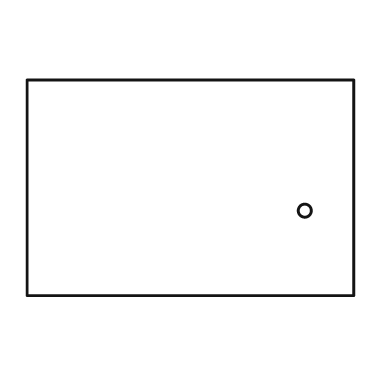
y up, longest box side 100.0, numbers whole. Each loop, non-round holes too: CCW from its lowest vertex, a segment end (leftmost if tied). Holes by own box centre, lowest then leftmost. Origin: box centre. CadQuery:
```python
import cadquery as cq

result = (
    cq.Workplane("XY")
    .moveTo(-50.0, -33.0)
    .lineTo(50.0, -33.0)
    .lineTo(50.0, 33.0)
    .lineTo(-50.0, 33.0)
    .close()
    .moveTo(35.0, -7.0)
    .circle(2.0)
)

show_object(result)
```